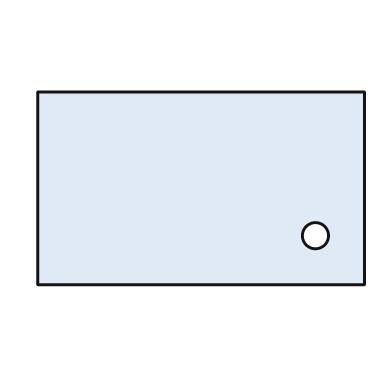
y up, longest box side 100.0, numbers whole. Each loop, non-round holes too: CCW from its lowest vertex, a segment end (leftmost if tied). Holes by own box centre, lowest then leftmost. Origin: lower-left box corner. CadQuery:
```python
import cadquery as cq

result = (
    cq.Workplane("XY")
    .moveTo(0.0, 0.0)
    .lineTo(100.0, 0.0)
    .lineTo(100.0, 59.0)
    .lineTo(0.0, 59.0)
    .close()
    .moveTo(85.0, 15.0)
    .circle(4.0)
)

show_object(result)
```